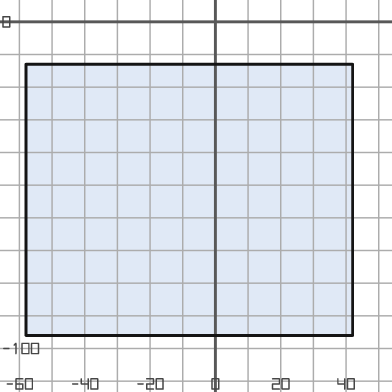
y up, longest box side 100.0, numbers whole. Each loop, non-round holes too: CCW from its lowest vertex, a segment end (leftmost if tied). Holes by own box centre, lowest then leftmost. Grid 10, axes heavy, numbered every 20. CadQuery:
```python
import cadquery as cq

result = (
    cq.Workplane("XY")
    .moveTo(-58.0, -96.0)
    .lineTo(42.0, -96.0)
    .lineTo(42.0, -13.0)
    .lineTo(-58.0, -13.0)
    .close()
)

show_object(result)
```